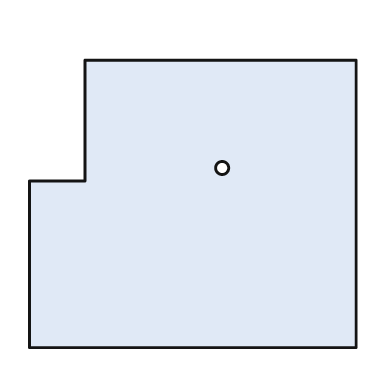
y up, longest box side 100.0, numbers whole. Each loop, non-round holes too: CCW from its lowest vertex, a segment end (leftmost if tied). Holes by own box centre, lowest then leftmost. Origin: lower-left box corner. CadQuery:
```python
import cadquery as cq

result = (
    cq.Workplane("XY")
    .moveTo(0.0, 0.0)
    .lineTo(100.0, 0.0)
    .lineTo(100.0, 88.0)
    .lineTo(17.0, 88.0)
    .lineTo(17.0, 51.0)
    .lineTo(0.0, 51.0)
    .close()
    .moveTo(59.0, 55.0)
    .circle(2.0)
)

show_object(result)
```